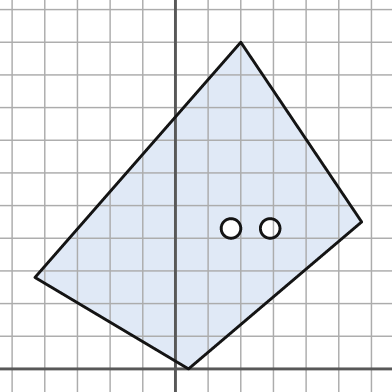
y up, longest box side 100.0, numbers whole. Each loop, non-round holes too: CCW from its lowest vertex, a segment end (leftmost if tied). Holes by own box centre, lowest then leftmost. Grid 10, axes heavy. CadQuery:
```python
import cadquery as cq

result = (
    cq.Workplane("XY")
    .moveTo(4.0, 0.0)
    .lineTo(57.0, 45.0)
    .lineTo(20.0, 100.0)
    .lineTo(-43.0, 28.0)
    .close()
    .moveTo(17.0, 43.0)
    .circle(3.0)
    .moveTo(29.0, 43.0)
    .circle(3.0)
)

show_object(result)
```